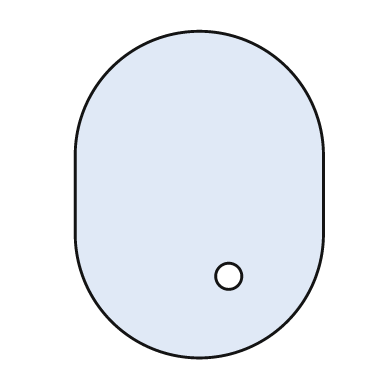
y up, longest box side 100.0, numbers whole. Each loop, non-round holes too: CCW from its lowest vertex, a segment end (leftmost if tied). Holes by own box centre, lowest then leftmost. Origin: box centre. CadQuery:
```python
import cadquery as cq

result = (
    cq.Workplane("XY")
    .moveTo(-38.0, -12.0)
    .threePointArc((0.0, -50.0), (38.0, -12.0))
    .lineTo(38.0, 12.0)
    .threePointArc((0.0, 50.0), (-38.0, 12.0))
    .close()
    .moveTo(9.0, -25.0)
    .circle(4.0)
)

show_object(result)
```